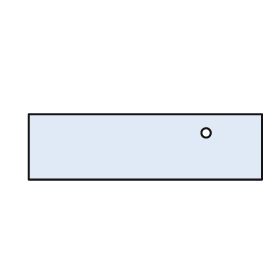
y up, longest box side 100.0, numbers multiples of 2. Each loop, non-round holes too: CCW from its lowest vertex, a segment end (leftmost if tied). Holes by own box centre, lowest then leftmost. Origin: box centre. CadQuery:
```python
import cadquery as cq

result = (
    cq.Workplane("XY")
    .moveTo(-50.0, -14.0)
    .lineTo(50.0, -14.0)
    .lineTo(50.0, 14.0)
    .lineTo(-50.0, 14.0)
    .close()
    .moveTo(26.0, 6.0)
    .circle(2.0)
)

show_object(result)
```